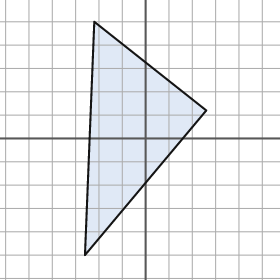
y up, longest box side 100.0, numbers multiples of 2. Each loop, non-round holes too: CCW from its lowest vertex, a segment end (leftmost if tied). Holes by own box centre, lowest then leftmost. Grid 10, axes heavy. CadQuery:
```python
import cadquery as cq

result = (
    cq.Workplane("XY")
    .moveTo(-26.0, -50.0)
    .lineTo(26.0, 12.0)
    .lineTo(-22.0, 50.0)
    .close()
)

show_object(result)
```